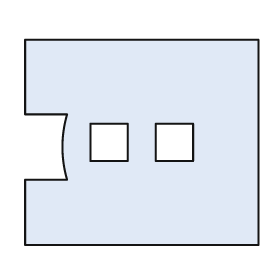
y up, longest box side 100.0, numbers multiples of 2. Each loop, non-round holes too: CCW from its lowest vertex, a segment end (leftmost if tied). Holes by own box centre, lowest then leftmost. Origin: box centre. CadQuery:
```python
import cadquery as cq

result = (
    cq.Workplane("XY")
    .moveTo(-50.0, -44.0)
    .lineTo(50.0, -44.0)
    .lineTo(50.0, 44.0)
    .lineTo(-50.0, 44.0)
    .lineTo(-50.0, 12.0)
    .lineTo(-32.0, 12.0)
    .threePointArc((-34.0, -2.0), (-32.0, -16.0))
    .lineTo(-50.0, -16.0)
    .close()
    .moveTo(-22.0, -8.0)
    .lineTo(-6.0, -8.0)
    .lineTo(-6.0, 8.0)
    .lineTo(-22.0, 8.0)
    .close()
    .moveTo(6.0, -8.0)
    .lineTo(22.0, -8.0)
    .lineTo(22.0, 8.0)
    .lineTo(6.0, 8.0)
    .close()
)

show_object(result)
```